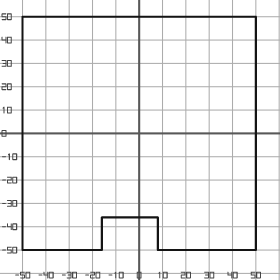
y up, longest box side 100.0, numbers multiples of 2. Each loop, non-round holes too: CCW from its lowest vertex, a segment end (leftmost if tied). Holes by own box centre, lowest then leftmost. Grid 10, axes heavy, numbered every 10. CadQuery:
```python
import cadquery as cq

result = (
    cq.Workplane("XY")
    .moveTo(-50.0, -50.0)
    .lineTo(-16.0, -50.0)
    .lineTo(-16.0, -36.0)
    .lineTo(8.0, -36.0)
    .lineTo(8.0, -50.0)
    .lineTo(50.0, -50.0)
    .lineTo(50.0, 50.0)
    .lineTo(-50.0, 50.0)
    .close()
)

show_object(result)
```